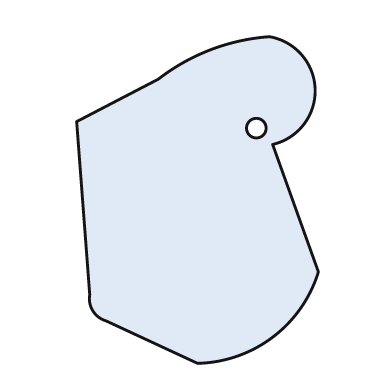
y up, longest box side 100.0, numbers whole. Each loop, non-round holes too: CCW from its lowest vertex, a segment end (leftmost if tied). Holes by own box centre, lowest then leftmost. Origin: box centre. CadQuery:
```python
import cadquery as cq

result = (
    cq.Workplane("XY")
    .moveTo(0.0, -50.0)
    .threePointArc((23.0, -42.0), (37.0, -22.0))
    .lineTo(23.0, 17.0)
    .threePointArc((36.0, 34.0), (22.0, 50.0))
    .threePointArc((4.0, 46.0), (-12.0, 37.0))
    .lineTo(-37.0, 24.0)
    .lineTo(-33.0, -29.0)
    .threePointArc((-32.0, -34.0), (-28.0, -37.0))
    .close()
    .moveTo(18.0, 22.0)
    .circle(3.0)
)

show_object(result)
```